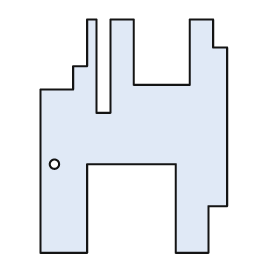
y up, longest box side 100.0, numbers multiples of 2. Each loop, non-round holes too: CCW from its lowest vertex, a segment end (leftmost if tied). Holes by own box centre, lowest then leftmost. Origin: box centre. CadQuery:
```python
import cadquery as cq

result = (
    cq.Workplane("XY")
    .moveTo(-40.0, -50.0)
    .lineTo(-20.0, -50.0)
    .lineTo(-20.0, -12.0)
    .lineTo(18.0, -12.0)
    .lineTo(18.0, -50.0)
    .lineTo(32.0, -50.0)
    .lineTo(32.0, -30.0)
    .lineTo(40.0, -30.0)
    .lineTo(40.0, 38.0)
    .lineTo(34.0, 38.0)
    .lineTo(34.0, 50.0)
    .lineTo(24.0, 50.0)
    .lineTo(24.0, 22.0)
    .lineTo(0.0, 22.0)
    .lineTo(0.0, 50.0)
    .lineTo(-10.0, 50.0)
    .lineTo(-10.0, 10.0)
    .lineTo(-16.0, 10.0)
    .lineTo(-16.0, 50.0)
    .lineTo(-20.0, 50.0)
    .lineTo(-20.0, 30.0)
    .lineTo(-26.0, 30.0)
    .lineTo(-26.0, 20.0)
    .lineTo(-40.0, 20.0)
    .close()
    .moveTo(-34.0, -12.0)
    .circle(2.0)
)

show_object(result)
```